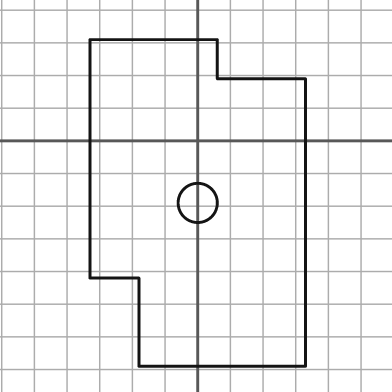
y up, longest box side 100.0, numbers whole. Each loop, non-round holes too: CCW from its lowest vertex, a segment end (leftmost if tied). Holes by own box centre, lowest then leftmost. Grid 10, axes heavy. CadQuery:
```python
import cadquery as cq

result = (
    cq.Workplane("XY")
    .moveTo(-18.0, -69.0)
    .lineTo(33.0, -69.0)
    .lineTo(33.0, 19.0)
    .lineTo(6.0, 19.0)
    .lineTo(6.0, 31.0)
    .lineTo(-33.0, 31.0)
    .lineTo(-33.0, -42.0)
    .lineTo(-18.0, -42.0)
    .close()
    .moveTo(0.0, -19.0)
    .circle(6.0)
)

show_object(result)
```